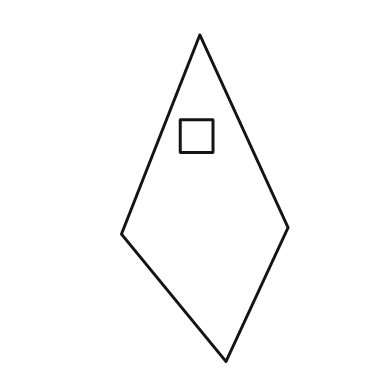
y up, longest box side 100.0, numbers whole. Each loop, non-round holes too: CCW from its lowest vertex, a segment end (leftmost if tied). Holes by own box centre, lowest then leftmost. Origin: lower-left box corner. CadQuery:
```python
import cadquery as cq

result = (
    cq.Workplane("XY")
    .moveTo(32.0, 0.0)
    .lineTo(51.0, 41.0)
    .lineTo(24.0, 100.0)
    .lineTo(0.0, 39.0)
    .close()
    .moveTo(18.0, 64.0)
    .lineTo(28.0, 64.0)
    .lineTo(28.0, 74.0)
    .lineTo(18.0, 74.0)
    .close()
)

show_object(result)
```